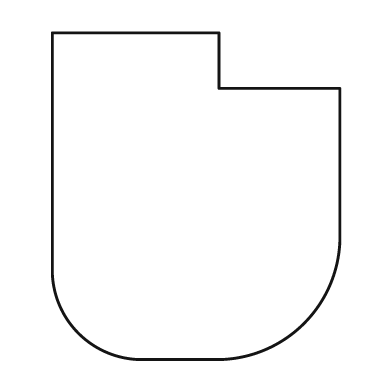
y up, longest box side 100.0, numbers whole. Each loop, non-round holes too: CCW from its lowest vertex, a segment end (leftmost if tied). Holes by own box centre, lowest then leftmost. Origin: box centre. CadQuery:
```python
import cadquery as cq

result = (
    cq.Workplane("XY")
    .moveTo(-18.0, -50.0)
    .lineTo(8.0, -50.0)
    .threePointArc((33.0, -39.0), (44.0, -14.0))
    .lineTo(44.0, 33.0)
    .lineTo(7.0, 33.0)
    .lineTo(7.0, 50.0)
    .lineTo(-44.0, 50.0)
    .lineTo(-44.0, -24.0)
    .threePointArc((-36.0, -42.0), (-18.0, -50.0))
    .close()
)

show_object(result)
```